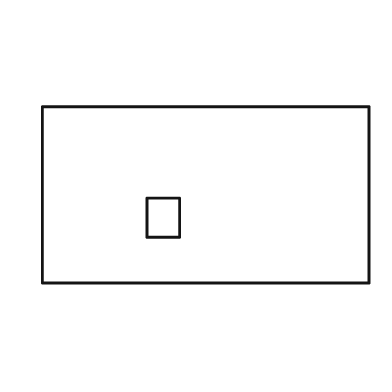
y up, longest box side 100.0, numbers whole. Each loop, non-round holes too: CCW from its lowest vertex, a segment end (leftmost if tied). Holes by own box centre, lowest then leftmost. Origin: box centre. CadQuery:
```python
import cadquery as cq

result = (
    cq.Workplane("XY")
    .moveTo(-50.0, -27.0)
    .lineTo(50.0, -27.0)
    .lineTo(50.0, 27.0)
    .lineTo(-50.0, 27.0)
    .close()
    .moveTo(-18.0, -13.0)
    .lineTo(-8.0, -13.0)
    .lineTo(-8.0, -1.0)
    .lineTo(-18.0, -1.0)
    .close()
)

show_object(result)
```